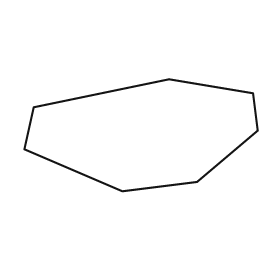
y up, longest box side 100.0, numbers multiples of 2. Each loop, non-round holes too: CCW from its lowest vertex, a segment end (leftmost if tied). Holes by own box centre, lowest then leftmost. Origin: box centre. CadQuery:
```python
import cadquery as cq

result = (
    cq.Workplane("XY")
    .moveTo(-8.0, -24.0)
    .lineTo(24.0, -20.0)
    .lineTo(50.0, 2.0)
    .lineTo(48.0, 18.0)
    .lineTo(12.0, 24.0)
    .lineTo(-46.0, 12.0)
    .lineTo(-50.0, -6.0)
    .close()
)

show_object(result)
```